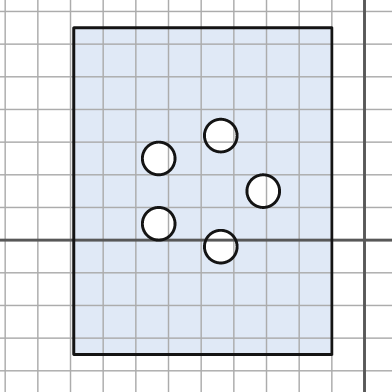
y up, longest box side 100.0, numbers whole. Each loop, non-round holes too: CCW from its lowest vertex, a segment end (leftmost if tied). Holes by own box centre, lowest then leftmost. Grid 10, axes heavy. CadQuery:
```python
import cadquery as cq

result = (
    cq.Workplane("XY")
    .moveTo(-89.0, -35.0)
    .lineTo(-10.0, -35.0)
    .lineTo(-10.0, 65.0)
    .lineTo(-89.0, 65.0)
    .close()
    .moveTo(-44.0, -2.0)
    .circle(5.0)
    .moveTo(-63.0, 5.0)
    .circle(5.0)
    .moveTo(-31.0, 15.0)
    .circle(5.0)
    .moveTo(-63.0, 25.0)
    .circle(5.0)
    .moveTo(-44.0, 32.0)
    .circle(5.0)
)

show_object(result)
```